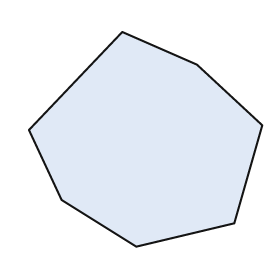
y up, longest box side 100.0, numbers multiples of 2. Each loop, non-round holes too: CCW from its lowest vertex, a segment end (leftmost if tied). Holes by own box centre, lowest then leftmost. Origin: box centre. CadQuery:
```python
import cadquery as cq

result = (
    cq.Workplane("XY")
    .moveTo(-4.0, -46.0)
    .lineTo(38.0, -36.0)
    .lineTo(50.0, 6.0)
    .lineTo(22.0, 32.0)
    .lineTo(-10.0, 46.0)
    .lineTo(-50.0, 4.0)
    .lineTo(-36.0, -26.0)
    .close()
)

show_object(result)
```